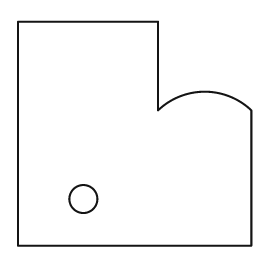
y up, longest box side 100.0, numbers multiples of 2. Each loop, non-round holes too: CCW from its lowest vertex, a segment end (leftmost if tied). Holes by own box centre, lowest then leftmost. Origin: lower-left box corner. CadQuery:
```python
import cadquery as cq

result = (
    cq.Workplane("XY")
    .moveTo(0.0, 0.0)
    .lineTo(100.0, 0.0)
    .lineTo(100.0, 58.0)
    .threePointArc((80.0, 66.0), (60.0, 58.0))
    .lineTo(60.0, 96.0)
    .lineTo(0.0, 96.0)
    .close()
    .moveTo(28.0, 20.0)
    .circle(6.0)
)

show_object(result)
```